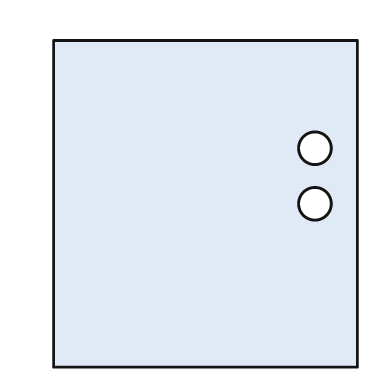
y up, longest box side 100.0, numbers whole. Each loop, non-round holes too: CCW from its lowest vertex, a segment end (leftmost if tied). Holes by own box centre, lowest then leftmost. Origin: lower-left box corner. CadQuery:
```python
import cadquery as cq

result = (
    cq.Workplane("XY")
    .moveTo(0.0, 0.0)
    .lineTo(93.0, 0.0)
    .lineTo(93.0, 100.0)
    .lineTo(0.0, 100.0)
    .close()
    .moveTo(80.0, 50.0)
    .circle(5.0)
    .moveTo(80.0, 67.0)
    .circle(5.0)
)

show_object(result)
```